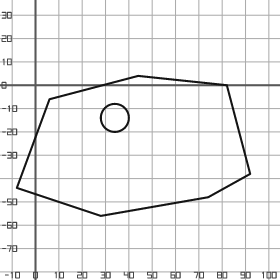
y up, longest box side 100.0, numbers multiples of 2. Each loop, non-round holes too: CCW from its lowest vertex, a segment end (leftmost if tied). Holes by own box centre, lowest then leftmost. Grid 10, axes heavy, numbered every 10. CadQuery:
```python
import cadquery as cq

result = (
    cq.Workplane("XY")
    .moveTo(28.0, -56.0)
    .lineTo(74.0, -48.0)
    .lineTo(92.0, -38.0)
    .lineTo(82.0, 0.0)
    .lineTo(44.0, 4.0)
    .lineTo(6.0, -6.0)
    .lineTo(-8.0, -44.0)
    .close()
    .moveTo(34.0, -14.0)
    .circle(6.0)
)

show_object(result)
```